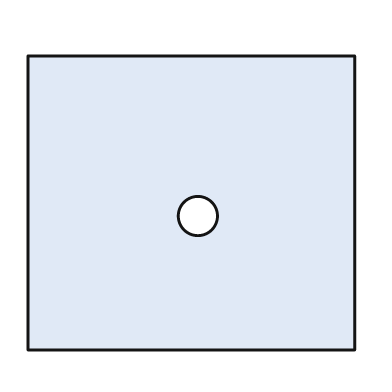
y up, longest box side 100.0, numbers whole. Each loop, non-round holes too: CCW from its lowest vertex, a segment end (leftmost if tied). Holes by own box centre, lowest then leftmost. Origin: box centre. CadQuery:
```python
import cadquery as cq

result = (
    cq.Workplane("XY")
    .moveTo(-50.0, -45.0)
    .lineTo(50.0, -45.0)
    .lineTo(50.0, 45.0)
    .lineTo(-50.0, 45.0)
    .close()
    .moveTo(2.0, -4.0)
    .circle(6.0)
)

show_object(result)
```